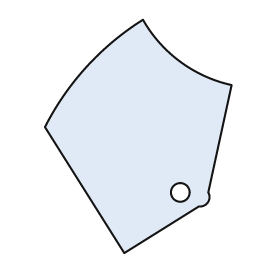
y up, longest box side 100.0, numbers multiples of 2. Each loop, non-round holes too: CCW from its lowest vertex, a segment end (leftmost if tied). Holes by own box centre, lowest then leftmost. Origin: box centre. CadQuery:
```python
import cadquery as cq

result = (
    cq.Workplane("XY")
    .moveTo(-6.0, -50.0)
    .lineTo(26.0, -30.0)
    .threePointArc((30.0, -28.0), (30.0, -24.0))
    .lineTo(40.0, 22.0)
    .threePointArc((18.0, 32.0), (2.0, 50.0))
    .threePointArc((-22.0, 30.0), (-40.0, 4.0))
    .close()
    .moveTo(18.0, -24.0)
    .circle(4.0)
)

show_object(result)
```